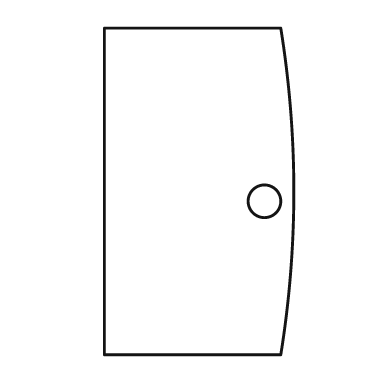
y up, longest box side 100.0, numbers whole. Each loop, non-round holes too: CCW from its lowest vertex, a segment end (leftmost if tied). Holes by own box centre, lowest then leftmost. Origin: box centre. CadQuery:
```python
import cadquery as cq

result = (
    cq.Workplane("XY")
    .moveTo(-29.0, -50.0)
    .lineTo(25.0, -50.0)
    .threePointArc((29.0, 0.0), (25.0, 50.0))
    .lineTo(-29.0, 50.0)
    .close()
    .moveTo(20.0, -3.0)
    .circle(5.0)
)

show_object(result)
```